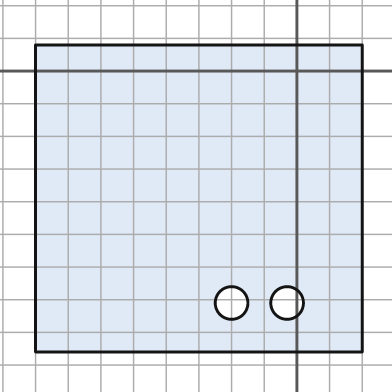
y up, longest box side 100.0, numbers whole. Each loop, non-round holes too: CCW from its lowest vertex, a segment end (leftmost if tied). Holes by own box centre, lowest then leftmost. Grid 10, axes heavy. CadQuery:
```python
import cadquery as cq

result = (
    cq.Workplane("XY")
    .moveTo(-80.0, -86.0)
    .lineTo(20.0, -86.0)
    .lineTo(20.0, 8.0)
    .lineTo(-80.0, 8.0)
    .close()
    .moveTo(-20.0, -71.0)
    .circle(5.0)
    .moveTo(-3.0, -71.0)
    .circle(5.0)
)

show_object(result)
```